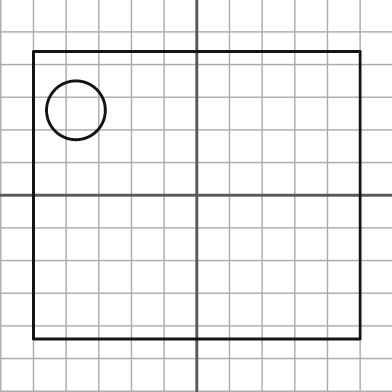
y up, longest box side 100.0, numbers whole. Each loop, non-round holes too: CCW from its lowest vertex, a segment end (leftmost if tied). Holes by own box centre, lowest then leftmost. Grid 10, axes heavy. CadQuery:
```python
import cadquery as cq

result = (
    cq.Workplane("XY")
    .moveTo(-50.0, -44.0)
    .lineTo(50.0, -44.0)
    .lineTo(50.0, 44.0)
    .lineTo(-50.0, 44.0)
    .close()
    .moveTo(-37.0, 26.0)
    .circle(9.0)
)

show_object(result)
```